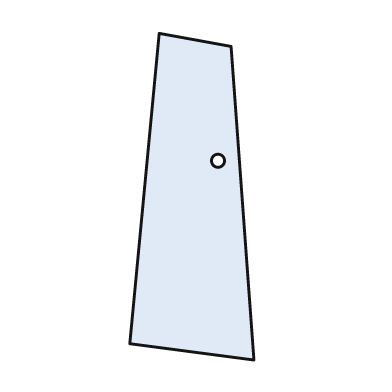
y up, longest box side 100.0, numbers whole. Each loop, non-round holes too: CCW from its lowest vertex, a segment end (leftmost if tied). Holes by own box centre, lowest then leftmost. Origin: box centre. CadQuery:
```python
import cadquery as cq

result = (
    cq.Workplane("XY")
    .moveTo(19.0, -50.0)
    .lineTo(12.0, 46.0)
    .lineTo(-10.0, 50.0)
    .lineTo(-19.0, -45.0)
    .close()
    .moveTo(8.0, 11.0)
    .circle(2.0)
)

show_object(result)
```